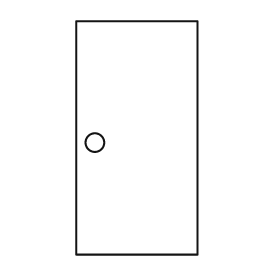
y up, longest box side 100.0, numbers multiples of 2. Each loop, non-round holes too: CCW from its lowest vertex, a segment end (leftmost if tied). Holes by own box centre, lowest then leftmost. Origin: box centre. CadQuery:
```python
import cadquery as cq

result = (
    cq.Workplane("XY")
    .moveTo(-26.0, -50.0)
    .lineTo(26.0, -50.0)
    .lineTo(26.0, 50.0)
    .lineTo(-26.0, 50.0)
    .close()
    .moveTo(-18.0, -2.0)
    .circle(4.0)
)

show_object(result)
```